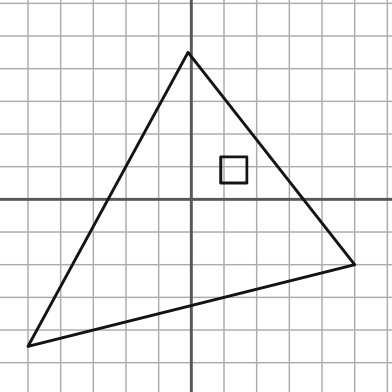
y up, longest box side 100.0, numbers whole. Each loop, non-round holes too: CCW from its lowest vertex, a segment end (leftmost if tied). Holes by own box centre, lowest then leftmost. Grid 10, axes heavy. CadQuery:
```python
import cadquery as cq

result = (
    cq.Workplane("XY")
    .moveTo(-50.0, -45.0)
    .lineTo(50.0, -20.0)
    .lineTo(-1.0, 45.0)
    .close()
    .moveTo(9.0, 5.0)
    .lineTo(17.0, 5.0)
    .lineTo(17.0, 13.0)
    .lineTo(9.0, 13.0)
    .close()
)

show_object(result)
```